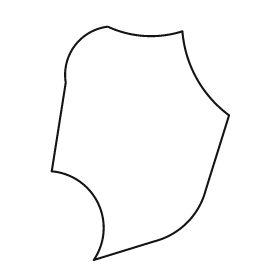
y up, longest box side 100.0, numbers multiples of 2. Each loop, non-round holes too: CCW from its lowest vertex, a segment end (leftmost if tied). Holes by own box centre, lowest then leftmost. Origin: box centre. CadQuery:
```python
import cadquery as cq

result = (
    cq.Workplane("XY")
    .moveTo(-20.0, -50.0)
    .lineTo(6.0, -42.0)
    .threePointArc((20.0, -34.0), (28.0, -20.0))
    .lineTo(38.0, 12.0)
    .threePointArc((24.0, 28.0), (18.0, 48.0))
    .threePointArc((2.0, 46.0), (-14.0, 50.0))
    .threePointArc((-28.0, 42.0), (-32.0, 26.0))
    .lineTo(-38.0, -12.0)
    .threePointArc((-18.0, -26.0), (-20.0, -50.0))
    .close()
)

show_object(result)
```